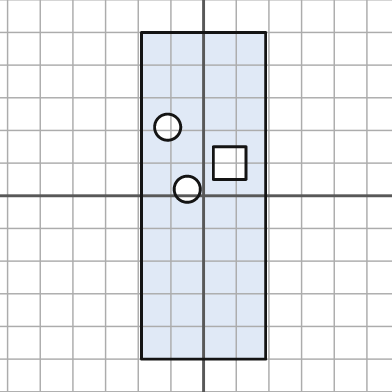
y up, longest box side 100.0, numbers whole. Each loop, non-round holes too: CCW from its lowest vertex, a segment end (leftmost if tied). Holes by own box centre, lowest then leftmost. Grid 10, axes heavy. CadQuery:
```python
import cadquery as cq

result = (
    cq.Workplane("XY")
    .moveTo(-19.0, -50.0)
    .lineTo(19.0, -50.0)
    .lineTo(19.0, 50.0)
    .lineTo(-19.0, 50.0)
    .close()
    .moveTo(-5.0, 2.0)
    .circle(4.0)
    .moveTo(3.0, 5.0)
    .lineTo(13.0, 5.0)
    .lineTo(13.0, 15.0)
    .lineTo(3.0, 15.0)
    .close()
    .moveTo(-11.0, 21.0)
    .circle(4.0)
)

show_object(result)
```